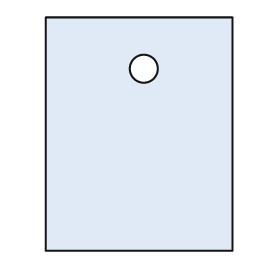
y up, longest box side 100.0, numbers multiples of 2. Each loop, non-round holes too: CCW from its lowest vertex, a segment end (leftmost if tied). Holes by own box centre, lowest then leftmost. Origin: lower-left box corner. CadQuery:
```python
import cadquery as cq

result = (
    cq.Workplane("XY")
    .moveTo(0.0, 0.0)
    .lineTo(80.0, 0.0)
    .lineTo(80.0, 100.0)
    .lineTo(0.0, 100.0)
    .close()
    .moveTo(42.0, 78.0)
    .circle(6.0)
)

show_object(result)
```